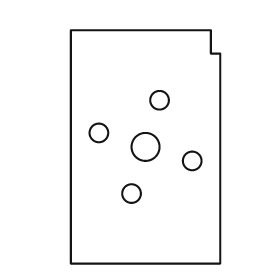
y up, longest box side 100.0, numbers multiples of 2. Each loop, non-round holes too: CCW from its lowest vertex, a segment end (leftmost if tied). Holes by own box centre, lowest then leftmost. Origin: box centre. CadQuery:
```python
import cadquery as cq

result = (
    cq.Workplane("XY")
    .moveTo(-32.0, -50.0)
    .lineTo(32.0, -50.0)
    .lineTo(32.0, 40.0)
    .lineTo(28.0, 40.0)
    .lineTo(28.0, 50.0)
    .lineTo(-32.0, 50.0)
    .close()
    .moveTo(-6.0, -20.0)
    .circle(4.0)
    .moveTo(20.0, -6.0)
    .circle(4.0)
    .moveTo(0.0, 0.0)
    .circle(6.0)
    .moveTo(-20.0, 6.0)
    .circle(4.0)
    .moveTo(6.0, 20.0)
    .circle(4.0)
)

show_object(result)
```